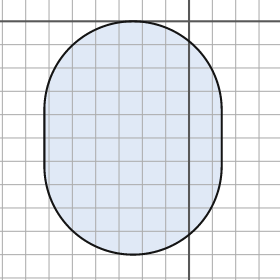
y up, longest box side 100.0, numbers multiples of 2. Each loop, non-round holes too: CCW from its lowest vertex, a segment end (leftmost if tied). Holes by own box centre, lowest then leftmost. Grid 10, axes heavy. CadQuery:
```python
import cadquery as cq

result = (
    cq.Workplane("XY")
    .moveTo(-62.0, -62.0)
    .threePointArc((-24.0, -100.0), (14.0, -62.0))
    .lineTo(14.0, -38.0)
    .threePointArc((-24.0, 0.0), (-62.0, -38.0))
    .close()
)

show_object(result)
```